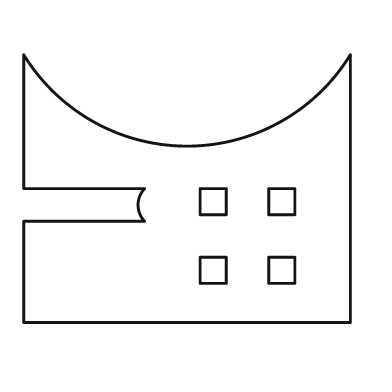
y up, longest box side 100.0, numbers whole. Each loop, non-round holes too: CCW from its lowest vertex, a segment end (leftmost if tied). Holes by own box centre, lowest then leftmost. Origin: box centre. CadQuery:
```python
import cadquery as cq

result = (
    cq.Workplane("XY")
    .moveTo(-50.0, -41.0)
    .lineTo(50.0, -41.0)
    .lineTo(50.0, 41.0)
    .threePointArc((0.0, 13.0), (-50.0, 41.0))
    .lineTo(-50.0, 0.0)
    .lineTo(-13.0, 0.0)
    .threePointArc((-15.0, -5.0), (-13.0, -10.0))
    .lineTo(-50.0, -10.0)
    .close()
    .moveTo(4.0, -29.0)
    .lineTo(12.0, -29.0)
    .lineTo(12.0, -21.0)
    .lineTo(4.0, -21.0)
    .close()
    .moveTo(25.0, -29.0)
    .lineTo(33.0, -29.0)
    .lineTo(33.0, -21.0)
    .lineTo(25.0, -21.0)
    .close()
    .moveTo(4.0, -8.0)
    .lineTo(12.0, -8.0)
    .lineTo(12.0, 0.0)
    .lineTo(4.0, 0.0)
    .close()
    .moveTo(25.0, -8.0)
    .lineTo(33.0, -8.0)
    .lineTo(33.0, 0.0)
    .lineTo(25.0, 0.0)
    .close()
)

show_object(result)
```